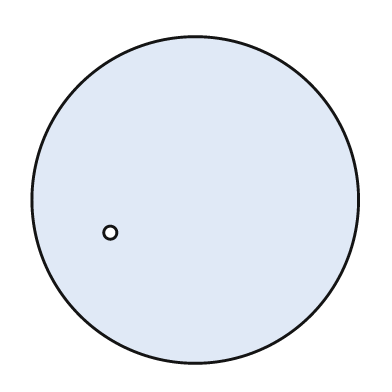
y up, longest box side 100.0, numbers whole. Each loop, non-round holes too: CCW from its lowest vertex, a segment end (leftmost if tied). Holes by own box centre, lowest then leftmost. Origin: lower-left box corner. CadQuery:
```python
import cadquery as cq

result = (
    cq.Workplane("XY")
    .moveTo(50.0, 50.0)
    .circle(50.0)
    .moveTo(24.0, 40.0)
    .circle(2.0)
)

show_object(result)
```